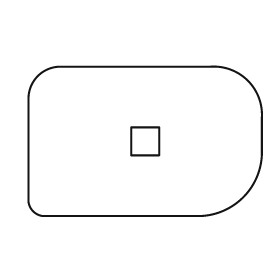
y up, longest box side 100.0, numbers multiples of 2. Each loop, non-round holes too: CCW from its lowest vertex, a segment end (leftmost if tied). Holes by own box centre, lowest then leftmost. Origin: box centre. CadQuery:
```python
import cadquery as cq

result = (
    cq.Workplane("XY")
    .moveTo(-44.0, -32.0)
    .lineTo(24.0, -32.0)
    .threePointArc((42.0, -24.0), (50.0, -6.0))
    .lineTo(50.0, 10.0)
    .threePointArc((44.0, 26.0), (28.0, 32.0))
    .lineTo(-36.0, 32.0)
    .threePointArc((-46.0, 28.0), (-50.0, 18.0))
    .lineTo(-50.0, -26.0)
    .threePointArc((-48.0, -30.0), (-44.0, -32.0))
    .close()
    .moveTo(-6.0, -6.0)
    .lineTo(6.0, -6.0)
    .lineTo(6.0, 6.0)
    .lineTo(-6.0, 6.0)
    .close()
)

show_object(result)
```